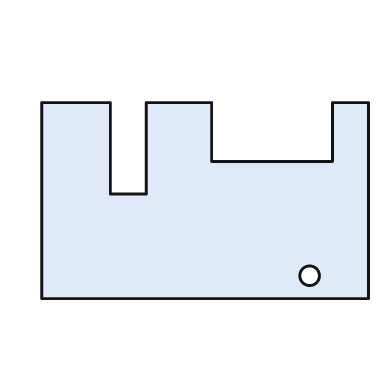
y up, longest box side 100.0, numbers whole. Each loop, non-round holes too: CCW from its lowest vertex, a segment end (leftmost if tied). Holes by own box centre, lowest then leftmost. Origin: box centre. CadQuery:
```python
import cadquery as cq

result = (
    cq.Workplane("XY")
    .moveTo(-50.0, -30.0)
    .lineTo(50.0, -30.0)
    .lineTo(50.0, 30.0)
    .lineTo(39.0, 30.0)
    .lineTo(39.0, 12.0)
    .lineTo(2.0, 12.0)
    .lineTo(2.0, 30.0)
    .lineTo(-18.0, 30.0)
    .lineTo(-18.0, 2.0)
    .lineTo(-29.0, 2.0)
    .lineTo(-29.0, 30.0)
    .lineTo(-50.0, 30.0)
    .close()
    .moveTo(32.0, -23.0)
    .circle(3.0)
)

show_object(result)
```